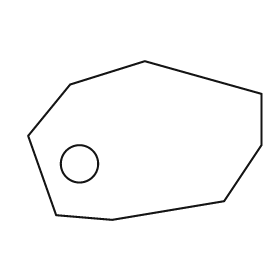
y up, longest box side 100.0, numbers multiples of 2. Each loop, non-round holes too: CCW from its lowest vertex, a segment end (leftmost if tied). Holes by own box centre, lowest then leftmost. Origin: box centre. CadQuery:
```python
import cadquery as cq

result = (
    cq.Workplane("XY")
    .moveTo(-14.0, -34.0)
    .lineTo(34.0, -26.0)
    .lineTo(50.0, -2.0)
    .lineTo(50.0, 20.0)
    .lineTo(0.0, 34.0)
    .lineTo(-32.0, 24.0)
    .lineTo(-50.0, 2.0)
    .lineTo(-38.0, -32.0)
    .close()
    .moveTo(-28.0, -10.0)
    .circle(8.0)
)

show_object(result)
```